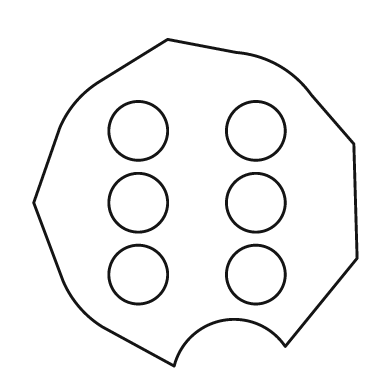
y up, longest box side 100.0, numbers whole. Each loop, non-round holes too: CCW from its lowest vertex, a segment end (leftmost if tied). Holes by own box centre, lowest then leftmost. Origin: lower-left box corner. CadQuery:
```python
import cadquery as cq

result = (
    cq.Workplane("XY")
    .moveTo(43.0, 0.0)
    .threePointArc((58.0, 14.0), (77.0, 6.0))
    .lineTo(99.0, 33.0)
    .lineTo(98.0, 68.0)
    .lineTo(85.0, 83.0)
    .threePointArc((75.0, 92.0), (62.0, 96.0))
    .lineTo(41.0, 100.0)
    .lineTo(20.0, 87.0)
    .threePointArc((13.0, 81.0), (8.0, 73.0))
    .lineTo(0.0, 50.0)
    .lineTo(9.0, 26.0)
    .threePointArc((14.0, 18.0), (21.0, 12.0))
    .close()
    .moveTo(32.0, 28.0)
    .circle(9.0)
    .moveTo(68.0, 28.0)
    .circle(9.0)
    .moveTo(32.0, 50.0)
    .circle(9.0)
    .moveTo(68.0, 50.0)
    .circle(9.0)
    .moveTo(32.0, 72.0)
    .circle(9.0)
    .moveTo(68.0, 72.0)
    .circle(9.0)
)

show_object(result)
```